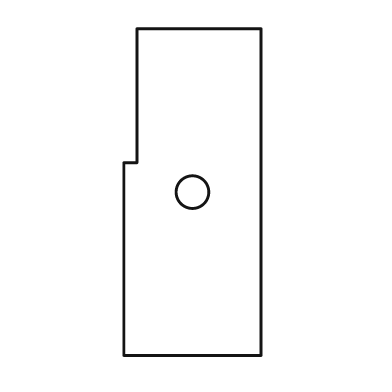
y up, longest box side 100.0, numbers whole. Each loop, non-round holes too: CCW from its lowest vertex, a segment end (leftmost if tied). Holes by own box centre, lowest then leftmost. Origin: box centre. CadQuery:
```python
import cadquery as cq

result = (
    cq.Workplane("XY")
    .moveTo(-21.0, -50.0)
    .lineTo(21.0, -50.0)
    .lineTo(21.0, 50.0)
    .lineTo(-17.0, 50.0)
    .lineTo(-17.0, 9.0)
    .lineTo(-21.0, 9.0)
    .close()
    .moveTo(0.0, 0.0)
    .circle(5.0)
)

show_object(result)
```